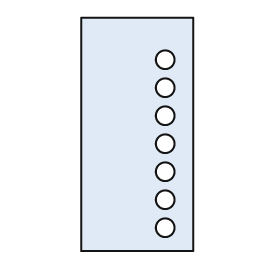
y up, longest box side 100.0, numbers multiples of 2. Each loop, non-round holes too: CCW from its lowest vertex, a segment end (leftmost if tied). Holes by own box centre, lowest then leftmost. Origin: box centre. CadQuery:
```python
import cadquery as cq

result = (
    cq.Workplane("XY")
    .moveTo(-24.0, -50.0)
    .lineTo(24.0, -50.0)
    .lineTo(24.0, 50.0)
    .lineTo(-24.0, 50.0)
    .close()
    .moveTo(12.0, -40.0)
    .circle(4.0)
    .moveTo(12.0, -28.0)
    .circle(4.0)
    .moveTo(12.0, -16.0)
    .circle(4.0)
    .moveTo(12.0, -4.0)
    .circle(4.0)
    .moveTo(12.0, 8.0)
    .circle(4.0)
    .moveTo(12.0, 20.0)
    .circle(4.0)
    .moveTo(12.0, 32.0)
    .circle(4.0)
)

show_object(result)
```